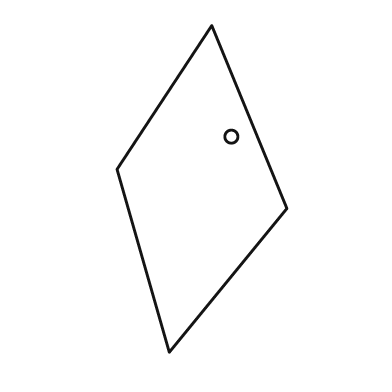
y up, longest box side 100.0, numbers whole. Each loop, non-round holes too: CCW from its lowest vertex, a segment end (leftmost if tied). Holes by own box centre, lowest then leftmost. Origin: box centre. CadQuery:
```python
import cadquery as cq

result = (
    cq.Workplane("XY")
    .moveTo(-10.0, -50.0)
    .lineTo(26.0, -6.0)
    .lineTo(3.0, 50.0)
    .lineTo(-26.0, 6.0)
    .close()
    .moveTo(9.0, 16.0)
    .circle(2.0)
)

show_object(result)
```